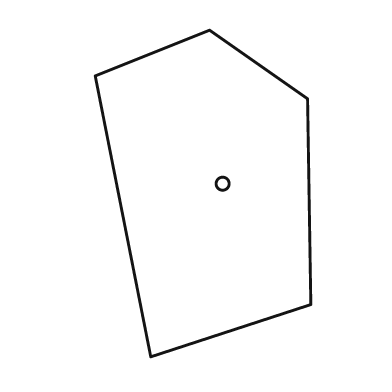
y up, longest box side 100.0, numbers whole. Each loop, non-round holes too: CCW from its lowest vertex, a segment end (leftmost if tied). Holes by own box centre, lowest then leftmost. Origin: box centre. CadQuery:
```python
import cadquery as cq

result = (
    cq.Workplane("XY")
    .moveTo(-16.0, -50.0)
    .lineTo(33.0, -34.0)
    .lineTo(32.0, 29.0)
    .lineTo(2.0, 50.0)
    .lineTo(-33.0, 36.0)
    .close()
    .moveTo(6.0, 3.0)
    .circle(2.0)
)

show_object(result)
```